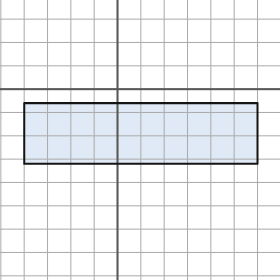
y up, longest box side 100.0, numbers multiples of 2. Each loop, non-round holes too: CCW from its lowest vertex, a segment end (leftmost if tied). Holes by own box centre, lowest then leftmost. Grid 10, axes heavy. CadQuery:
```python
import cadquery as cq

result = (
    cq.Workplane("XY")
    .moveTo(-40.0, -32.0)
    .lineTo(60.0, -32.0)
    .lineTo(60.0, -6.0)
    .lineTo(-40.0, -6.0)
    .close()
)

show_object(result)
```